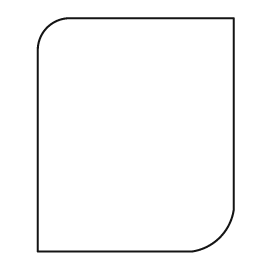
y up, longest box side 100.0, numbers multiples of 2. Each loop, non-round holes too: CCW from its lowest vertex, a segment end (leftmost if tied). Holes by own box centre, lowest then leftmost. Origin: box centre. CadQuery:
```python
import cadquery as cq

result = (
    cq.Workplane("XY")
    .moveTo(-42.0, -50.0)
    .lineTo(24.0, -50.0)
    .threePointArc((36.0, -44.0), (42.0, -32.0))
    .lineTo(42.0, 50.0)
    .lineTo(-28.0, 50.0)
    .threePointArc((-38.0, 46.0), (-42.0, 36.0))
    .close()
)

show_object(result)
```